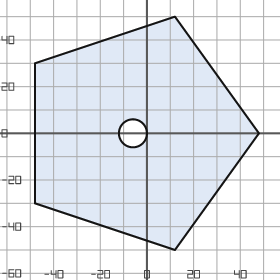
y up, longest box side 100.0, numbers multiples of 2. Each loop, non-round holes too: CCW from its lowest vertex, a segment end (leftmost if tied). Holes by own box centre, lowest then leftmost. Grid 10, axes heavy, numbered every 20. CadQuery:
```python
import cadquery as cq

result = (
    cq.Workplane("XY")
    .moveTo(12.0, -50.0)
    .lineTo(48.0, 0.0)
    .lineTo(12.0, 50.0)
    .lineTo(-48.0, 30.0)
    .lineTo(-48.0, -30.0)
    .close()
    .moveTo(-6.0, 0.0)
    .circle(6.0)
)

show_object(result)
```